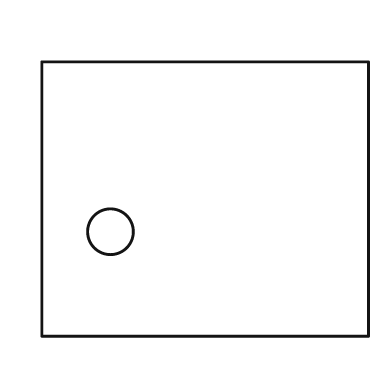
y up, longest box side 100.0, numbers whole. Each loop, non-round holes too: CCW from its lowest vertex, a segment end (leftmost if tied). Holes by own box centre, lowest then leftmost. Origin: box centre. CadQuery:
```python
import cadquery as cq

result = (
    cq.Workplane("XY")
    .moveTo(-50.0, -42.0)
    .lineTo(50.0, -42.0)
    .lineTo(50.0, 42.0)
    .lineTo(-50.0, 42.0)
    .close()
    .moveTo(-29.0, -10.0)
    .circle(7.0)
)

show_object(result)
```